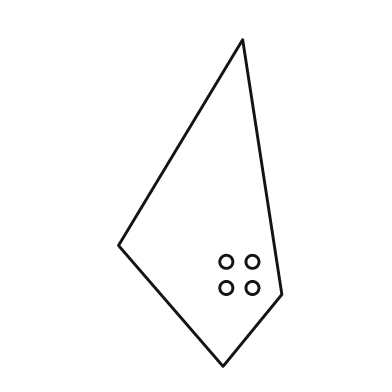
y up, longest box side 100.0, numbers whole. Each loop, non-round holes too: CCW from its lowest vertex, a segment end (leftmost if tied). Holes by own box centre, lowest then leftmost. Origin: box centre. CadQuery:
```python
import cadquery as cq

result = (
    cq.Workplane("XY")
    .moveTo(7.0, -50.0)
    .lineTo(25.0, -28.0)
    .lineTo(13.0, 50.0)
    .lineTo(-25.0, -13.0)
    .close()
    .moveTo(8.0, -26.0)
    .circle(2.0)
    .moveTo(16.0, -26.0)
    .circle(2.0)
    .moveTo(8.0, -18.0)
    .circle(2.0)
    .moveTo(16.0, -18.0)
    .circle(2.0)
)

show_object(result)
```